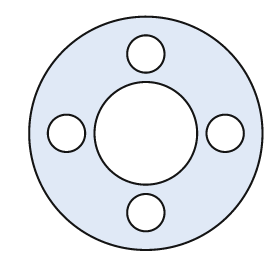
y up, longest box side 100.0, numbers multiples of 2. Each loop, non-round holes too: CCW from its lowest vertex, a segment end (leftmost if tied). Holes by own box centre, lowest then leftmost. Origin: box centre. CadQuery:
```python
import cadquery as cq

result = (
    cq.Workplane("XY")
    .moveTo(0.0, 0.0)
    .circle(50.0)
    .moveTo(0.0, -34.0)
    .circle(8.0)
    .moveTo(-34.0, 0.0)
    .circle(8.0)
    .moveTo(0.0, 0.0)
    .circle(22.0)
    .moveTo(34.0, 0.0)
    .circle(8.0)
    .moveTo(0.0, 34.0)
    .circle(8.0)
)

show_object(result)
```